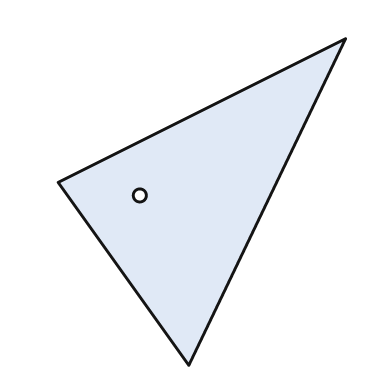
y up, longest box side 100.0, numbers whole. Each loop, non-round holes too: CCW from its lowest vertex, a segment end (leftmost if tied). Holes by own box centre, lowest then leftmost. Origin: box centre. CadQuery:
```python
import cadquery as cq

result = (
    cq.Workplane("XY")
    .moveTo(-4.0, -50.0)
    .lineTo(44.0, 50.0)
    .lineTo(-44.0, 6.0)
    .close()
    .moveTo(-19.0, 2.0)
    .circle(2.0)
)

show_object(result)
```